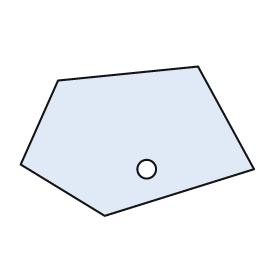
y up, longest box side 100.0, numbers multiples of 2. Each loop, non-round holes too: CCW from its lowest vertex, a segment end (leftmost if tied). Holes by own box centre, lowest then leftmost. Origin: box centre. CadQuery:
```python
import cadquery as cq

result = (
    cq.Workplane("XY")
    .moveTo(-14.0, -32.0)
    .lineTo(50.0, -12.0)
    .lineTo(26.0, 32.0)
    .lineTo(-34.0, 26.0)
    .lineTo(-50.0, -10.0)
    .close()
    .moveTo(4.0, -12.0)
    .circle(4.0)
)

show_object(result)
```